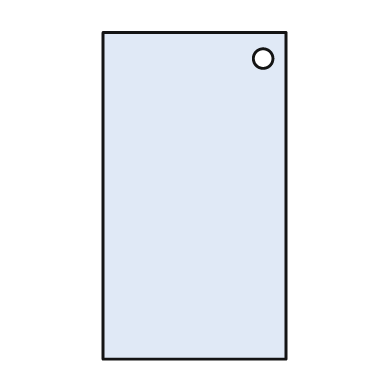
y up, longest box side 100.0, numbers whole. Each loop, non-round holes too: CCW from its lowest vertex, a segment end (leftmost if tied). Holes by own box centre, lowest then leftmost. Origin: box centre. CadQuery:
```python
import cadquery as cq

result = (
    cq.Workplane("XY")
    .moveTo(-28.0, -50.0)
    .lineTo(28.0, -50.0)
    .lineTo(28.0, 50.0)
    .lineTo(-28.0, 50.0)
    .close()
    .moveTo(21.0, 42.0)
    .circle(3.0)
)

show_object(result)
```